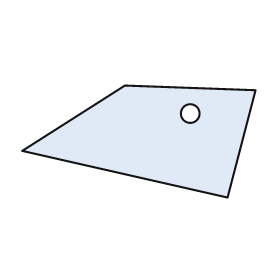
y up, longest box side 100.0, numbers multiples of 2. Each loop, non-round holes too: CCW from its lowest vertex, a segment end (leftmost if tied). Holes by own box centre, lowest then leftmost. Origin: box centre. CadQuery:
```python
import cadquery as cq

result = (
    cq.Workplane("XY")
    .moveTo(38.0, -24.0)
    .lineTo(50.0, 22.0)
    .lineTo(-6.0, 24.0)
    .lineTo(-50.0, -4.0)
    .close()
    .moveTo(22.0, 12.0)
    .circle(4.0)
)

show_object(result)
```